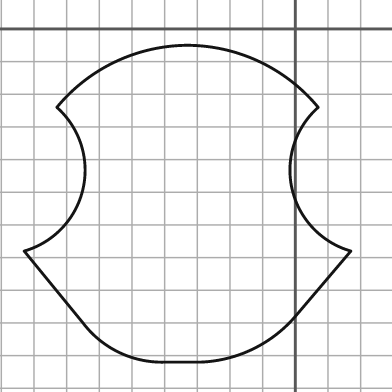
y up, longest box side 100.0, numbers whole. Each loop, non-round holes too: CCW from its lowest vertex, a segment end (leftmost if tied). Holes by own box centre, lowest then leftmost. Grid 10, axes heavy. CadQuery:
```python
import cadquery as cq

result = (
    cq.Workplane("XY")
    .moveTo(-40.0, -102.0)
    .lineTo(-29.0, -102.0)
    .threePointArc((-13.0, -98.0), (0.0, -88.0))
    .lineTo(17.0, -68.0)
    .threePointArc((-1.0, -49.0), (7.0, -24.0))
    .threePointArc((-11.0, -10.0), (-33.0, -5.0))
    .threePointArc((-55.0, -10.0), (-73.0, -24.0))
    .threePointArc((-65.0, -49.0), (-83.0, -68.0))
    .lineTo(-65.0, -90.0)
    .threePointArc((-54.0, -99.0), (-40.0, -102.0))
    .close()
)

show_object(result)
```